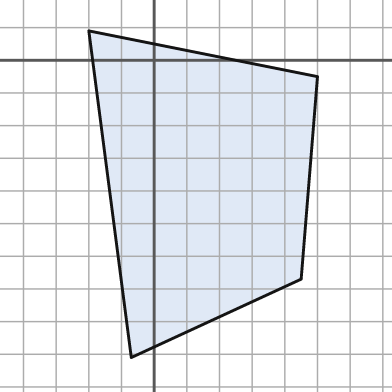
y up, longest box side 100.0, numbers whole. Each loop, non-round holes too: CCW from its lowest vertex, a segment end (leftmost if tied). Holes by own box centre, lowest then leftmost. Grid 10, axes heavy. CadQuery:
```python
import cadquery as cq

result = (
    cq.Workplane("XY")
    .moveTo(-7.0, -91.0)
    .lineTo(45.0, -67.0)
    .lineTo(50.0, -5.0)
    .lineTo(-20.0, 9.0)
    .close()
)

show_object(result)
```